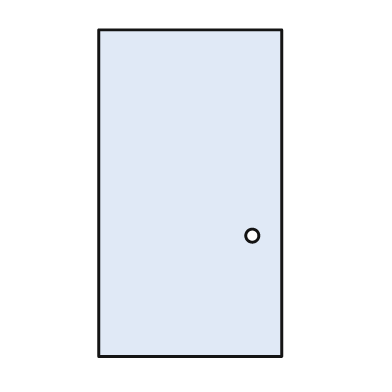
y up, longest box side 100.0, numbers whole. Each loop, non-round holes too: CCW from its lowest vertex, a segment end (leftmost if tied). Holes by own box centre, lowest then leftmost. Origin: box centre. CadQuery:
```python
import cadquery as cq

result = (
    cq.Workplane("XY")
    .moveTo(-28.0, -50.0)
    .lineTo(28.0, -50.0)
    .lineTo(28.0, 50.0)
    .lineTo(-28.0, 50.0)
    .close()
    .moveTo(19.0, -13.0)
    .circle(2.0)
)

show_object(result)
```